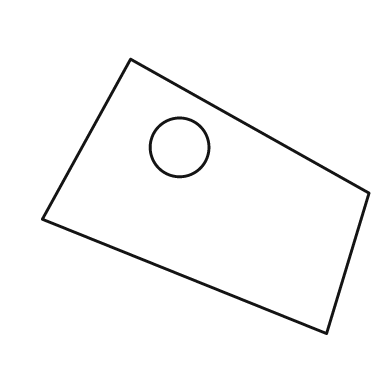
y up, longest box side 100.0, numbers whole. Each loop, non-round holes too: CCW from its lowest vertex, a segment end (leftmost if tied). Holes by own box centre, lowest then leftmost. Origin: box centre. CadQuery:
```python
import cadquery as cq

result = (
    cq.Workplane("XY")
    .moveTo(37.0, -42.0)
    .lineTo(50.0, 1.0)
    .lineTo(-23.0, 42.0)
    .lineTo(-50.0, -7.0)
    .close()
    .moveTo(-8.0, 15.0)
    .circle(9.0)
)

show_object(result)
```